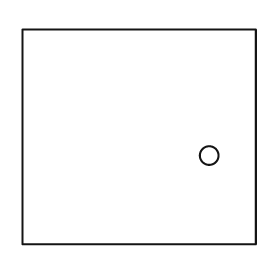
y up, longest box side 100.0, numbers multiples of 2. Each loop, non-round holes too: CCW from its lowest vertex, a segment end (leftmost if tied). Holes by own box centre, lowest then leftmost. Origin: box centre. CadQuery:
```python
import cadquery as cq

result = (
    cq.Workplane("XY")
    .moveTo(-50.0, -46.0)
    .lineTo(50.0, -46.0)
    .lineTo(50.0, 46.0)
    .lineTo(-50.0, 46.0)
    .close()
    .moveTo(30.0, -8.0)
    .circle(4.0)
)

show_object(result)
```